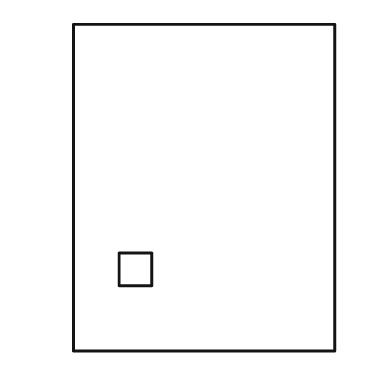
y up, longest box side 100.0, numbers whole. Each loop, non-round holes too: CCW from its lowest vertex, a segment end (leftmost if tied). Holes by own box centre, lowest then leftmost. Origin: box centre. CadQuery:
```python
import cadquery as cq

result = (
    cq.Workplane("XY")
    .moveTo(-40.0, -50.0)
    .lineTo(40.0, -50.0)
    .lineTo(40.0, 50.0)
    .lineTo(-40.0, 50.0)
    .close()
    .moveTo(-26.0, -30.0)
    .lineTo(-16.0, -30.0)
    .lineTo(-16.0, -20.0)
    .lineTo(-26.0, -20.0)
    .close()
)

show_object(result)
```